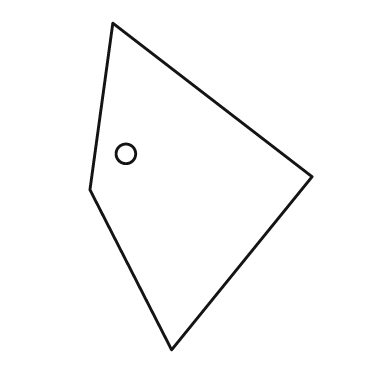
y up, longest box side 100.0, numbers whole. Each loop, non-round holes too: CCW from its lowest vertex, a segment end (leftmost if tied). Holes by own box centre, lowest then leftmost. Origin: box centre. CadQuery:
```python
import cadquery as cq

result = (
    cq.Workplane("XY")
    .moveTo(-9.0, -50.0)
    .lineTo(34.0, 3.0)
    .lineTo(-27.0, 50.0)
    .lineTo(-34.0, -1.0)
    .close()
    .moveTo(-23.0, 10.0)
    .circle(3.0)
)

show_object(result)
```